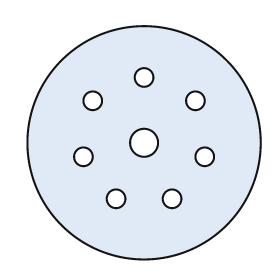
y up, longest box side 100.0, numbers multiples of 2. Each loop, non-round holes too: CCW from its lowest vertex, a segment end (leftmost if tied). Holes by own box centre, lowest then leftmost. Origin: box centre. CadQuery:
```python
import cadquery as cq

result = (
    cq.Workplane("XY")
    .moveTo(0.0, 0.0)
    .circle(50.0)
    .moveTo(-12.0, -24.0)
    .circle(4.0)
    .moveTo(12.0, -24.0)
    .circle(4.0)
    .moveTo(-26.0, -6.0)
    .circle(4.0)
    .moveTo(26.0, -6.0)
    .circle(4.0)
    .moveTo(0.0, 0.0)
    .circle(6.0)
    .moveTo(-22.0, 18.0)
    .circle(4.0)
    .moveTo(22.0, 18.0)
    .circle(4.0)
    .moveTo(0.0, 28.0)
    .circle(4.0)
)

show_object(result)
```